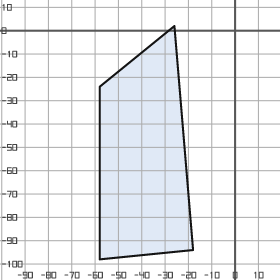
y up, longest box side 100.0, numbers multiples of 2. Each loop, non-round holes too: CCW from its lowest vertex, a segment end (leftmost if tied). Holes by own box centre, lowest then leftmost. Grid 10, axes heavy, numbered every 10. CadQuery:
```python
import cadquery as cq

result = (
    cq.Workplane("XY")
    .moveTo(-58.0, -98.0)
    .lineTo(-18.0, -94.0)
    .lineTo(-26.0, 2.0)
    .lineTo(-58.0, -24.0)
    .close()
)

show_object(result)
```